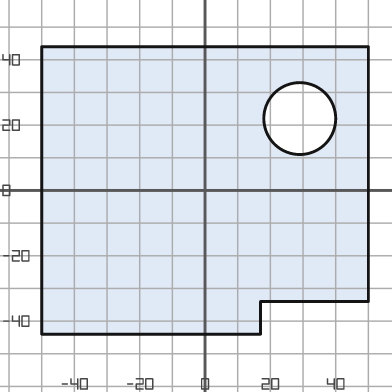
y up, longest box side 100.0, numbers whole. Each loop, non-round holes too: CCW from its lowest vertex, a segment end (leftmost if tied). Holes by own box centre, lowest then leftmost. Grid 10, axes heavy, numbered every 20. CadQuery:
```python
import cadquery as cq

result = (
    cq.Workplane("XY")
    .moveTo(-50.0, -44.0)
    .lineTo(17.0, -44.0)
    .lineTo(17.0, -34.0)
    .lineTo(50.0, -34.0)
    .lineTo(50.0, 44.0)
    .lineTo(-50.0, 44.0)
    .close()
    .moveTo(29.0, 22.0)
    .circle(11.0)
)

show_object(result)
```